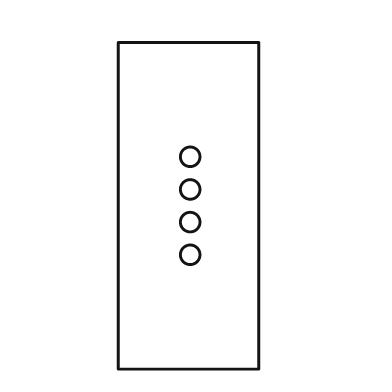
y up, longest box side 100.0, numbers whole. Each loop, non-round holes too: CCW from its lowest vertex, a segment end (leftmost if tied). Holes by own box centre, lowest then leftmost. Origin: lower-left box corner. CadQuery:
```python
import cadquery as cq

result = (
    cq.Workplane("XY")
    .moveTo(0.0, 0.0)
    .lineTo(43.0, 0.0)
    .lineTo(43.0, 100.0)
    .lineTo(0.0, 100.0)
    .close()
    .moveTo(22.0, 35.0)
    .circle(3.0)
    .moveTo(22.0, 45.0)
    .circle(3.0)
    .moveTo(22.0, 55.0)
    .circle(3.0)
    .moveTo(22.0, 65.0)
    .circle(3.0)
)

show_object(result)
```